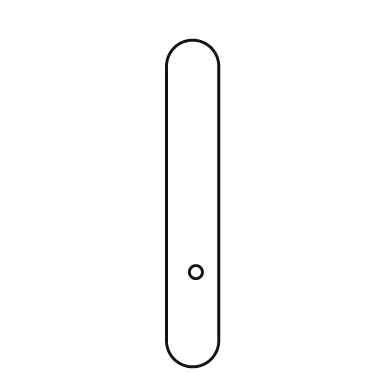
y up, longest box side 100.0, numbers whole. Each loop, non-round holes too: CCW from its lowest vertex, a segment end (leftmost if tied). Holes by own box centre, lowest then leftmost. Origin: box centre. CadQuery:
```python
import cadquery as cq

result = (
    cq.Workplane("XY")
    .moveTo(-8.0, -42.0)
    .threePointArc((0.0, -50.0), (8.0, -42.0))
    .lineTo(8.0, 42.0)
    .threePointArc((0.0, 50.0), (-8.0, 42.0))
    .close()
    .moveTo(1.0, -21.0)
    .circle(2.0)
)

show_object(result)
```